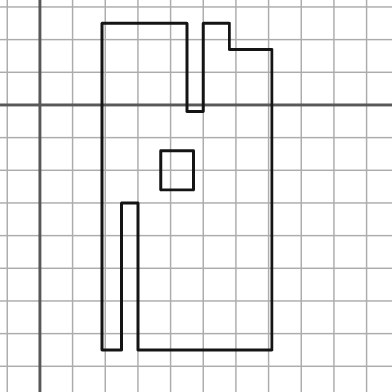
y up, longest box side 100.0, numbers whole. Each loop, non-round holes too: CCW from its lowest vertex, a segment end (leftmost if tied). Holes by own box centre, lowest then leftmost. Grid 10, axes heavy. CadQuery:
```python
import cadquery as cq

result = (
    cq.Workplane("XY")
    .moveTo(19.0, -75.0)
    .lineTo(25.0, -75.0)
    .lineTo(25.0, -30.0)
    .lineTo(30.0, -30.0)
    .lineTo(30.0, -75.0)
    .lineTo(71.0, -75.0)
    .lineTo(71.0, 17.0)
    .lineTo(58.0, 17.0)
    .lineTo(58.0, 25.0)
    .lineTo(50.0, 25.0)
    .lineTo(50.0, -2.0)
    .lineTo(45.0, -2.0)
    .lineTo(45.0, 25.0)
    .lineTo(19.0, 25.0)
    .close()
    .moveTo(37.0, -26.0)
    .lineTo(47.0, -26.0)
    .lineTo(47.0, -14.0)
    .lineTo(37.0, -14.0)
    .close()
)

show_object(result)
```